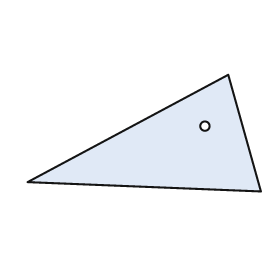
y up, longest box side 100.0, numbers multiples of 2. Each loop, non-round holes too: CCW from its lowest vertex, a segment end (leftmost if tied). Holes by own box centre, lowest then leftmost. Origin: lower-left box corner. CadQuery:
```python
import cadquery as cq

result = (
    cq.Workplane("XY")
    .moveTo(100.0, 0.0)
    .lineTo(86.0, 50.0)
    .lineTo(0.0, 4.0)
    .close()
    .moveTo(76.0, 28.0)
    .circle(2.0)
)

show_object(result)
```